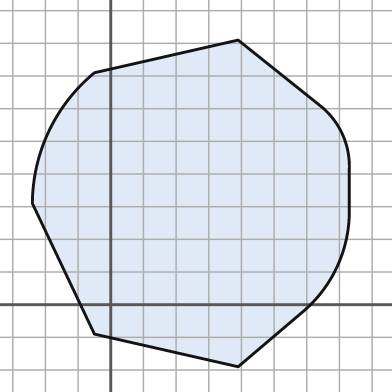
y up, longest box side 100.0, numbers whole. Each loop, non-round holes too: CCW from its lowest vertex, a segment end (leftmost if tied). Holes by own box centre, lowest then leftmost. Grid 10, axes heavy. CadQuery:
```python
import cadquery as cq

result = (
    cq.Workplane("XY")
    .moveTo(39.0, -19.0)
    .lineTo(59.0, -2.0)
    .threePointArc((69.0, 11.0), (73.0, 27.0))
    .lineTo(73.0, 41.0)
    .threePointArc((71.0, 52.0), (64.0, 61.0))
    .lineTo(39.0, 81.0)
    .lineTo(-5.0, 71.0)
    .threePointArc((-19.0, 53.0), (-24.0, 31.0))
    .lineTo(-5.0, -9.0)
    .close()
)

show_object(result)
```